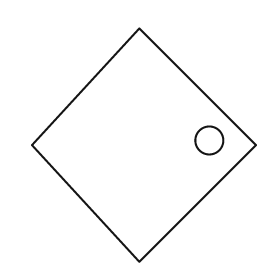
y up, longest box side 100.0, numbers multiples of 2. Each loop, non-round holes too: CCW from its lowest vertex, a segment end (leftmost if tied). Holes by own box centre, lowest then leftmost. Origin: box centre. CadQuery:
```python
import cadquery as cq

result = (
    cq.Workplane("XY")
    .moveTo(-2.0, -50.0)
    .lineTo(48.0, 0.0)
    .lineTo(-2.0, 50.0)
    .lineTo(-48.0, 0.0)
    .close()
    .moveTo(28.0, 2.0)
    .circle(6.0)
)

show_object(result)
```